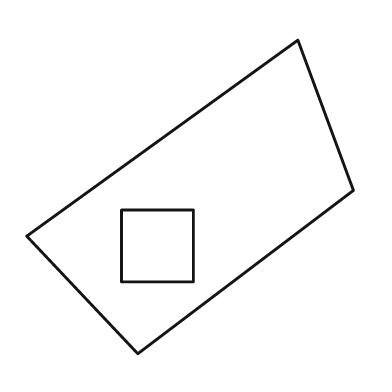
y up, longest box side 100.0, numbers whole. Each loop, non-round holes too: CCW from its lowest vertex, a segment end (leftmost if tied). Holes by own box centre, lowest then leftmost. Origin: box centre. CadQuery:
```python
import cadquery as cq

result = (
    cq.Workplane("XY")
    .moveTo(-16.0, -48.0)
    .lineTo(50.0, 2.0)
    .lineTo(33.0, 48.0)
    .lineTo(-50.0, -12.0)
    .close()
    .moveTo(-21.0, -26.0)
    .lineTo(1.0, -26.0)
    .lineTo(1.0, -4.0)
    .lineTo(-21.0, -4.0)
    .close()
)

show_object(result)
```